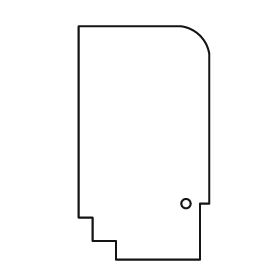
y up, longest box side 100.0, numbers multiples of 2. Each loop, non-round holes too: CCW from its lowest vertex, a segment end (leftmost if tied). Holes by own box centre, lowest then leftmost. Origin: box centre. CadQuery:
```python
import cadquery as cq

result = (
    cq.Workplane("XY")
    .moveTo(-12.0, -50.0)
    .lineTo(24.0, -50.0)
    .lineTo(24.0, -26.0)
    .lineTo(28.0, -26.0)
    .lineTo(28.0, 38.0)
    .threePointArc((24.0, 46.0), (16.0, 50.0))
    .lineTo(-28.0, 50.0)
    .lineTo(-28.0, -32.0)
    .lineTo(-22.0, -32.0)
    .lineTo(-22.0, -42.0)
    .lineTo(-12.0, -42.0)
    .close()
    .moveTo(18.0, -26.0)
    .circle(2.0)
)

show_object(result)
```